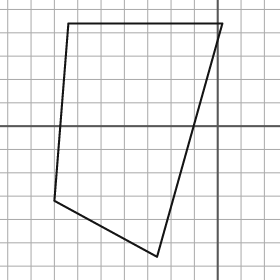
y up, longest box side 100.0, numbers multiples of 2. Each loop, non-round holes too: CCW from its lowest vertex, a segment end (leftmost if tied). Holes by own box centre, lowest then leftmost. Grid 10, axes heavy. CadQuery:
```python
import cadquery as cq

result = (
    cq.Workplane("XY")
    .moveTo(-26.0, -56.0)
    .lineTo(2.0, 44.0)
    .lineTo(-64.0, 44.0)
    .lineTo(-70.0, -32.0)
    .close()
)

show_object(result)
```